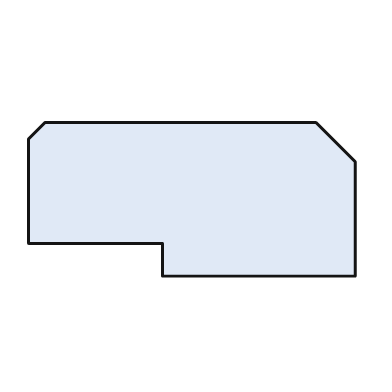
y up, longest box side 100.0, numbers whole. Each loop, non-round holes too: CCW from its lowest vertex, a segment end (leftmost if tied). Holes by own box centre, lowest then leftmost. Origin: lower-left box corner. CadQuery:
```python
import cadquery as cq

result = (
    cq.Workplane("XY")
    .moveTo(41.0, 0.0)
    .lineTo(100.0, 0.0)
    .lineTo(100.0, 35.0)
    .lineTo(88.0, 47.0)
    .lineTo(5.0, 47.0)
    .lineTo(0.0, 42.0)
    .lineTo(0.0, 10.0)
    .lineTo(41.0, 10.0)
    .close()
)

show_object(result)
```